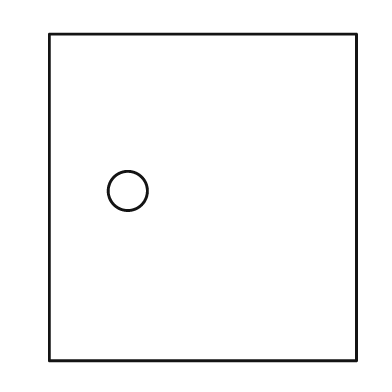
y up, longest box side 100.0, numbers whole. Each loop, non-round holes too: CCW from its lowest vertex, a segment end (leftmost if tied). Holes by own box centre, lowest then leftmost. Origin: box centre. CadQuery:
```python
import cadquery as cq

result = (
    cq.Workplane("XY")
    .moveTo(-47.0, -50.0)
    .lineTo(47.0, -50.0)
    .lineTo(47.0, 50.0)
    .lineTo(-47.0, 50.0)
    .close()
    .moveTo(-23.0, 2.0)
    .circle(6.0)
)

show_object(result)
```